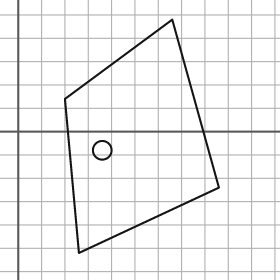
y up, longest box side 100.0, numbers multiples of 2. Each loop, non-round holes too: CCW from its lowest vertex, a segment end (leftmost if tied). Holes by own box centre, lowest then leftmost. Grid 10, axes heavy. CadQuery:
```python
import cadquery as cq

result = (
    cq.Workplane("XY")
    .moveTo(26.0, -52.0)
    .lineTo(86.0, -24.0)
    .lineTo(66.0, 48.0)
    .lineTo(20.0, 14.0)
    .close()
    .moveTo(36.0, -8.0)
    .circle(4.0)
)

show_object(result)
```